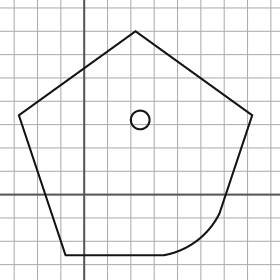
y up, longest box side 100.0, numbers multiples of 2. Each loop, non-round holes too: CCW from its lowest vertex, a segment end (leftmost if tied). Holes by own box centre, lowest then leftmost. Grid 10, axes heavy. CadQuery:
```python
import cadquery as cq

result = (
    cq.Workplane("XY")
    .moveTo(-8.0, -26.0)
    .lineTo(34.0, -26.0)
    .threePointArc((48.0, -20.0), (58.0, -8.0))
    .lineTo(72.0, 34.0)
    .lineTo(22.0, 70.0)
    .lineTo(-28.0, 34.0)
    .close()
    .moveTo(24.0, 32.0)
    .circle(4.0)
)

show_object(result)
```